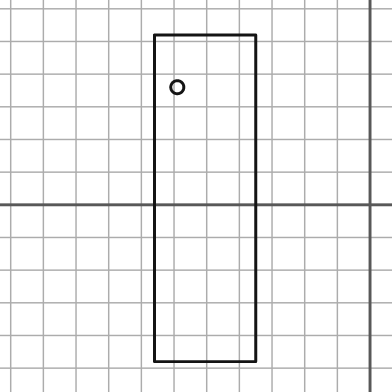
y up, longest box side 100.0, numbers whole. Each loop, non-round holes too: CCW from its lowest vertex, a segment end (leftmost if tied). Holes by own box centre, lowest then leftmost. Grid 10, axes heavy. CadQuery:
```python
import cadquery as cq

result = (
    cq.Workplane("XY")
    .moveTo(-66.0, -48.0)
    .lineTo(-35.0, -48.0)
    .lineTo(-35.0, 52.0)
    .lineTo(-66.0, 52.0)
    .close()
    .moveTo(-59.0, 36.0)
    .circle(2.0)
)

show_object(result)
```